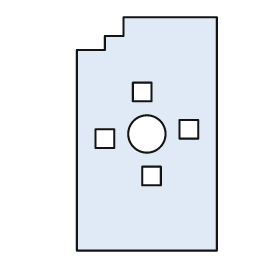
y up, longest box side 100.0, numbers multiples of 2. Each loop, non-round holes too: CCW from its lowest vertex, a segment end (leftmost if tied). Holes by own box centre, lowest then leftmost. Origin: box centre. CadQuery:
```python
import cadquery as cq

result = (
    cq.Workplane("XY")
    .moveTo(-30.0, -50.0)
    .lineTo(30.0, -50.0)
    .lineTo(30.0, 50.0)
    .lineTo(-10.0, 50.0)
    .lineTo(-10.0, 42.0)
    .lineTo(-18.0, 42.0)
    .lineTo(-18.0, 36.0)
    .lineTo(-30.0, 36.0)
    .close()
    .moveTo(-2.0, -22.0)
    .lineTo(6.0, -22.0)
    .lineTo(6.0, -14.0)
    .lineTo(-2.0, -14.0)
    .close()
    .moveTo(-22.0, -6.0)
    .lineTo(-14.0, -6.0)
    .lineTo(-14.0, 2.0)
    .lineTo(-22.0, 2.0)
    .close()
    .moveTo(0.0, 0.0)
    .circle(8.0)
    .moveTo(14.0, -2.0)
    .lineTo(22.0, -2.0)
    .lineTo(22.0, 6.0)
    .lineTo(14.0, 6.0)
    .close()
    .moveTo(-6.0, 14.0)
    .lineTo(2.0, 14.0)
    .lineTo(2.0, 22.0)
    .lineTo(-6.0, 22.0)
    .close()
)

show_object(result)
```